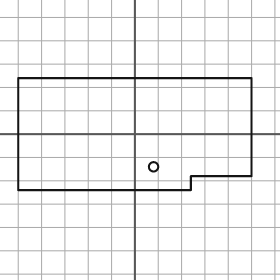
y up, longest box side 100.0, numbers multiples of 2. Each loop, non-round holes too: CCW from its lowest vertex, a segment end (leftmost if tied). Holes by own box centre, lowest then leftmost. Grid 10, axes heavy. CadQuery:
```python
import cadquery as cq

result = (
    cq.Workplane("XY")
    .moveTo(-50.0, -24.0)
    .lineTo(24.0, -24.0)
    .lineTo(24.0, -18.0)
    .lineTo(50.0, -18.0)
    .lineTo(50.0, 24.0)
    .lineTo(-50.0, 24.0)
    .close()
    .moveTo(8.0, -14.0)
    .circle(2.0)
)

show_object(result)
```